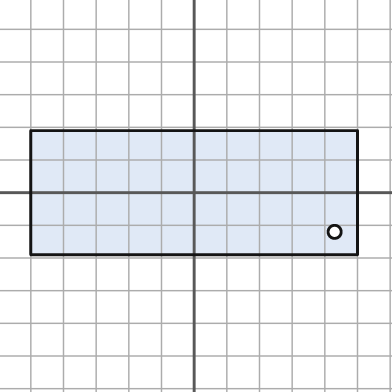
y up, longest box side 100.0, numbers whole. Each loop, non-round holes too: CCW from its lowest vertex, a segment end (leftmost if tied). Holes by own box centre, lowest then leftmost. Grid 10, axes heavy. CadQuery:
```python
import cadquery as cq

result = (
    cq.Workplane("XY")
    .moveTo(-50.0, -19.0)
    .lineTo(50.0, -19.0)
    .lineTo(50.0, 19.0)
    .lineTo(-50.0, 19.0)
    .close()
    .moveTo(43.0, -12.0)
    .circle(2.0)
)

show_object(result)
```